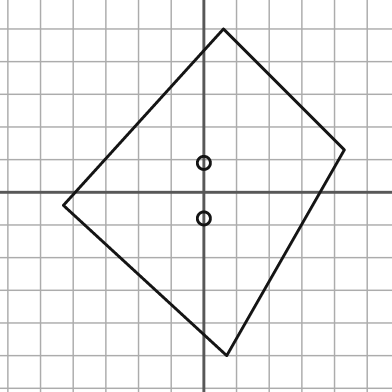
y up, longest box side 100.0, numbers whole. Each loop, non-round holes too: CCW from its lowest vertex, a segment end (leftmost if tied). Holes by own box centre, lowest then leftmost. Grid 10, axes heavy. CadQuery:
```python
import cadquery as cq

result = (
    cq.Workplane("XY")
    .moveTo(7.0, -50.0)
    .lineTo(43.0, 13.0)
    .lineTo(6.0, 50.0)
    .lineTo(-43.0, -4.0)
    .close()
    .moveTo(0.0, -8.0)
    .circle(2.0)
    .moveTo(0.0, 9.0)
    .circle(2.0)
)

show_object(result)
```